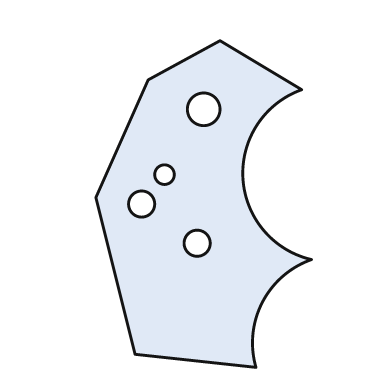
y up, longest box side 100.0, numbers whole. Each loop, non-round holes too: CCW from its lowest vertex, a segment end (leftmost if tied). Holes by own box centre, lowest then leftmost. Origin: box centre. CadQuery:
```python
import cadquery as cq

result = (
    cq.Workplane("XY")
    .moveTo(16.0, -50.0)
    .threePointArc((18.0, -30.0), (33.0, -17.0))
    .threePointArc((12.0, 8.0), (30.0, 35.0))
    .lineTo(5.0, 50.0)
    .lineTo(-17.0, 38.0)
    .lineTo(-33.0, 2.0)
    .lineTo(-21.0, -46.0)
    .close()
    .moveTo(-2.0, -12.0)
    .circle(4.0)
    .moveTo(-19.0, 0.0)
    .circle(4.0)
    .moveTo(-12.0, 9.0)
    .circle(3.0)
    .moveTo(0.0, 29.0)
    .circle(5.0)
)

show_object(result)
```